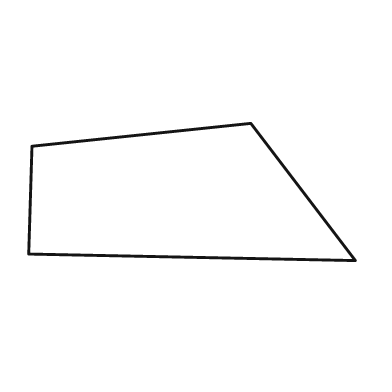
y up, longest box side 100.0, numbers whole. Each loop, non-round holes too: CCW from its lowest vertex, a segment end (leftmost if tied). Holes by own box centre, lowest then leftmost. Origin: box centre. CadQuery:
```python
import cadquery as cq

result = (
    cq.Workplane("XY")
    .moveTo(50.0, -21.0)
    .lineTo(18.0, 21.0)
    .lineTo(-49.0, 14.0)
    .lineTo(-50.0, -19.0)
    .close()
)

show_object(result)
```